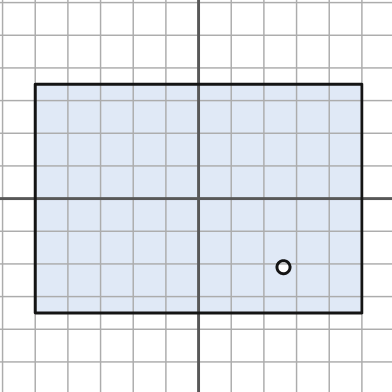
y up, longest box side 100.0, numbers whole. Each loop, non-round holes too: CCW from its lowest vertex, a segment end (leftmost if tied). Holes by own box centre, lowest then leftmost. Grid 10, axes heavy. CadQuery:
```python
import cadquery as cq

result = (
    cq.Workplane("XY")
    .moveTo(-50.0, -35.0)
    .lineTo(50.0, -35.0)
    .lineTo(50.0, 35.0)
    .lineTo(-50.0, 35.0)
    .close()
    .moveTo(26.0, -21.0)
    .circle(2.0)
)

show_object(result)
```